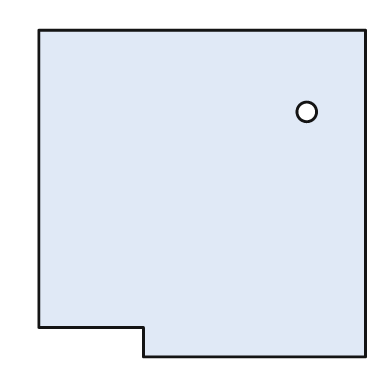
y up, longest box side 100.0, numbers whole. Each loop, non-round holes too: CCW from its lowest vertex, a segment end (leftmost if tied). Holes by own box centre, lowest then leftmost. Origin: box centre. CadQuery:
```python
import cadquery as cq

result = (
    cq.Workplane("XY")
    .moveTo(-18.0, -50.0)
    .lineTo(50.0, -50.0)
    .lineTo(50.0, 50.0)
    .lineTo(-50.0, 50.0)
    .lineTo(-50.0, -41.0)
    .lineTo(-18.0, -41.0)
    .close()
    .moveTo(32.0, 25.0)
    .circle(3.0)
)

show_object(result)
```